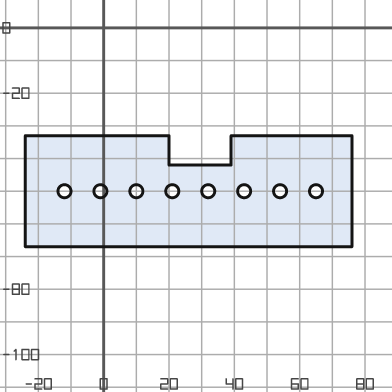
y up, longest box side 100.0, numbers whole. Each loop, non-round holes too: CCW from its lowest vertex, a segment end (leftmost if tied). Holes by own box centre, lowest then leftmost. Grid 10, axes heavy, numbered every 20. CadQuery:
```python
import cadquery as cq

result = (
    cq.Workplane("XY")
    .moveTo(-24.0, -67.0)
    .lineTo(76.0, -67.0)
    .lineTo(76.0, -33.0)
    .lineTo(39.0, -33.0)
    .lineTo(39.0, -42.0)
    .lineTo(20.0, -42.0)
    .lineTo(20.0, -33.0)
    .lineTo(-24.0, -33.0)
    .close()
    .moveTo(-12.0, -50.0)
    .circle(2.0)
    .moveTo(-1.0, -50.0)
    .circle(2.0)
    .moveTo(10.0, -50.0)
    .circle(2.0)
    .moveTo(21.0, -50.0)
    .circle(2.0)
    .moveTo(32.0, -50.0)
    .circle(2.0)
    .moveTo(43.0, -50.0)
    .circle(2.0)
    .moveTo(54.0, -50.0)
    .circle(2.0)
    .moveTo(65.0, -50.0)
    .circle(2.0)
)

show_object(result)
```